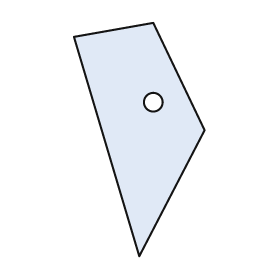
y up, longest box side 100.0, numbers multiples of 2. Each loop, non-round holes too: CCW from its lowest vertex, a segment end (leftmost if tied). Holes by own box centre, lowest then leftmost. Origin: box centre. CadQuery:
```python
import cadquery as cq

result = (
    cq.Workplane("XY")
    .moveTo(0.0, -50.0)
    .lineTo(28.0, 4.0)
    .lineTo(6.0, 50.0)
    .lineTo(-28.0, 44.0)
    .close()
    .moveTo(6.0, 16.0)
    .circle(4.0)
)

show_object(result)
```